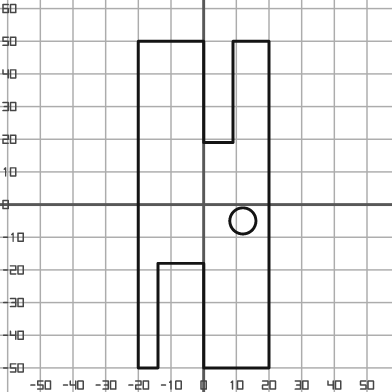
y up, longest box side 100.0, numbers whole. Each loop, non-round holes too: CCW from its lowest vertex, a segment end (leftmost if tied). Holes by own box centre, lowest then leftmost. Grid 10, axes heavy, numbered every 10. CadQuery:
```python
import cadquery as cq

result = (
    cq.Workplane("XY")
    .moveTo(-20.0, -50.0)
    .lineTo(-14.0, -50.0)
    .lineTo(-14.0, -18.0)
    .lineTo(0.0, -18.0)
    .lineTo(0.0, -50.0)
    .lineTo(20.0, -50.0)
    .lineTo(20.0, 50.0)
    .lineTo(9.0, 50.0)
    .lineTo(9.0, 19.0)
    .lineTo(0.0, 19.0)
    .lineTo(0.0, 50.0)
    .lineTo(-20.0, 50.0)
    .close()
    .moveTo(12.0, -5.0)
    .circle(4.0)
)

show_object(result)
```